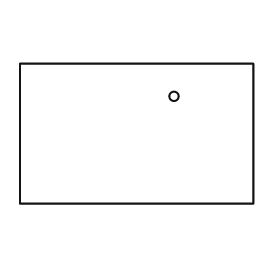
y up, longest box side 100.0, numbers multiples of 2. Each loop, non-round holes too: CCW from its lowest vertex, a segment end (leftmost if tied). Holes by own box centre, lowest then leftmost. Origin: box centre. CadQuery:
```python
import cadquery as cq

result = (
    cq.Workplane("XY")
    .moveTo(-50.0, -30.0)
    .lineTo(50.0, -30.0)
    .lineTo(50.0, 30.0)
    .lineTo(-50.0, 30.0)
    .close()
    .moveTo(16.0, 16.0)
    .circle(2.0)
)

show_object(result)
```